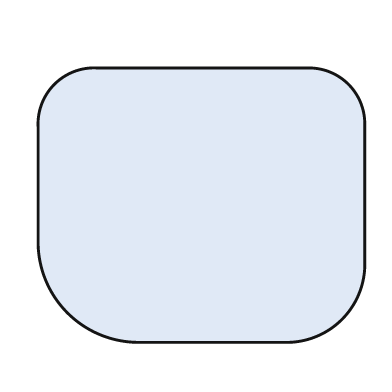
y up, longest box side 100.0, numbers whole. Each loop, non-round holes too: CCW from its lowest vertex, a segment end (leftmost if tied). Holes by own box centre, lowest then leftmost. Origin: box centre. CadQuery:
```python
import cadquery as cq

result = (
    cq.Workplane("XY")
    .moveTo(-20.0, -42.0)
    .lineTo(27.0, -42.0)
    .threePointArc((43.0, -35.0), (50.0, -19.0))
    .lineTo(50.0, 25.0)
    .threePointArc((45.0, 37.0), (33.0, 42.0))
    .lineTo(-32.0, 42.0)
    .threePointArc((-45.0, 37.0), (-50.0, 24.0))
    .lineTo(-50.0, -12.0)
    .threePointArc((-41.0, -33.0), (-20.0, -42.0))
    .close()
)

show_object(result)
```